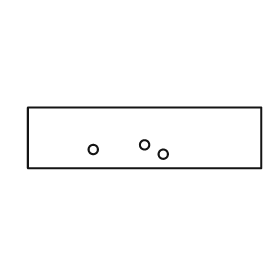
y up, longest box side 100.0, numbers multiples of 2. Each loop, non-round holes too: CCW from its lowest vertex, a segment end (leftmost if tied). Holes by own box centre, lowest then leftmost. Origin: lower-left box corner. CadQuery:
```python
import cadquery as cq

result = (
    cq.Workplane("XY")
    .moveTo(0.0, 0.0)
    .lineTo(100.0, 0.0)
    .lineTo(100.0, 26.0)
    .lineTo(0.0, 26.0)
    .close()
    .moveTo(58.0, 6.0)
    .circle(2.0)
    .moveTo(28.0, 8.0)
    .circle(2.0)
    .moveTo(50.0, 10.0)
    .circle(2.0)
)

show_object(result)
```